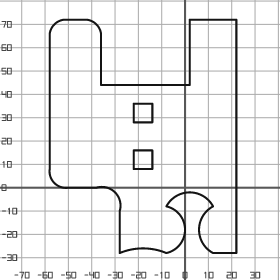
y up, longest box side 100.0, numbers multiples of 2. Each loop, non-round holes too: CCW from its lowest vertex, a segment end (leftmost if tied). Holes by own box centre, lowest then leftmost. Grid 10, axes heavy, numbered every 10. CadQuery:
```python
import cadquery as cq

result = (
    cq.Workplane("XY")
    .moveTo(-28.0, -28.0)
    .threePointArc((-18.0, -26.0), (-8.0, -28.0))
    .threePointArc((0.0, -18.0), (-8.0, -8.0))
    .threePointArc((2.0, -2.0), (12.0, -8.0))
    .threePointArc((6.0, -18.0), (12.0, -28.0))
    .lineTo(22.0, -28.0)
    .lineTo(22.0, 72.0)
    .lineTo(2.0, 72.0)
    .lineTo(2.0, 44.0)
    .lineTo(-36.0, 44.0)
    .lineTo(-36.0, 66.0)
    .threePointArc((-38.0, 70.0), (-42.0, 72.0))
    .lineTo(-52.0, 72.0)
    .threePointArc((-56.0, 70.0), (-58.0, 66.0))
    .lineTo(-58.0, 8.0)
    .threePointArc((-56.0, 2.0), (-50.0, 0.0))
    .lineTo(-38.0, 0.0)
    .threePointArc((-30.0, -2.0), (-28.0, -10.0))
    .close()
    .moveTo(-22.0, 8.0)
    .lineTo(-14.0, 8.0)
    .lineTo(-14.0, 16.0)
    .lineTo(-22.0, 16.0)
    .close()
    .moveTo(-22.0, 28.0)
    .lineTo(-14.0, 28.0)
    .lineTo(-14.0, 36.0)
    .lineTo(-22.0, 36.0)
    .close()
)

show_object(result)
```